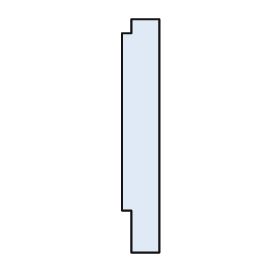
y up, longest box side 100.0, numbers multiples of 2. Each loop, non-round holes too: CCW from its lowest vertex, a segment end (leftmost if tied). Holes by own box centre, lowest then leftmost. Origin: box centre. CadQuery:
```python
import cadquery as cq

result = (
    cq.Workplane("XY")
    .moveTo(-4.0, -50.0)
    .lineTo(8.0, -50.0)
    .lineTo(8.0, 50.0)
    .lineTo(-4.0, 50.0)
    .lineTo(-4.0, 44.0)
    .lineTo(-8.0, 44.0)
    .lineTo(-8.0, -32.0)
    .lineTo(-4.0, -32.0)
    .close()
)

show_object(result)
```